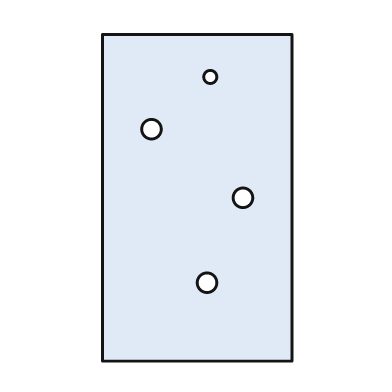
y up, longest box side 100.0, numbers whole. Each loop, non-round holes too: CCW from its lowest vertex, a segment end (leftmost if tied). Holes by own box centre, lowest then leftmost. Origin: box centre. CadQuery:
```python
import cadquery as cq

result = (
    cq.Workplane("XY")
    .moveTo(-29.0, -50.0)
    .lineTo(29.0, -50.0)
    .lineTo(29.0, 50.0)
    .lineTo(-29.0, 50.0)
    .close()
    .moveTo(3.0, -26.0)
    .circle(3.0)
    .moveTo(14.0, 0.0)
    .circle(3.0)
    .moveTo(-14.0, 21.0)
    .circle(3.0)
    .moveTo(4.0, 37.0)
    .circle(2.0)
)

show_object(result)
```